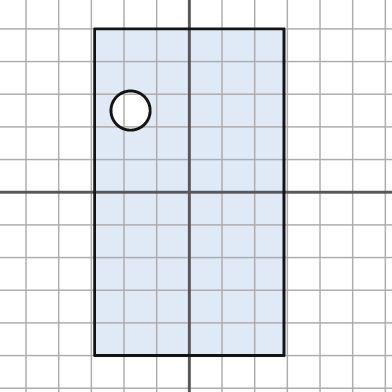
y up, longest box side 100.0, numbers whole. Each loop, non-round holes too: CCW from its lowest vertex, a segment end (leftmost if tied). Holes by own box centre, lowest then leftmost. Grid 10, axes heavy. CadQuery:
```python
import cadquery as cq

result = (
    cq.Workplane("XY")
    .moveTo(-29.0, -50.0)
    .lineTo(29.0, -50.0)
    .lineTo(29.0, 50.0)
    .lineTo(-29.0, 50.0)
    .close()
    .moveTo(-18.0, 25.0)
    .circle(6.0)
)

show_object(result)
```